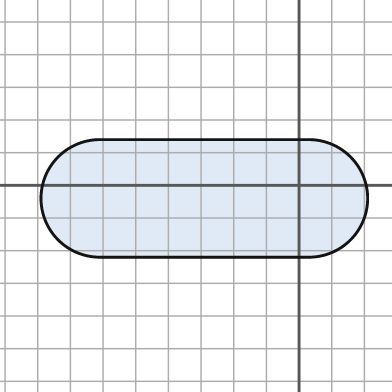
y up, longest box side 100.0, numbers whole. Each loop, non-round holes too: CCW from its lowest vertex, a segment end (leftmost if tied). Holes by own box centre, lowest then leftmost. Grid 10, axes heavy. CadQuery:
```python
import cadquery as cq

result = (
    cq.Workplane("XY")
    .moveTo(-61.0, -22.0)
    .lineTo(3.0, -22.0)
    .threePointArc((21.0, -4.0), (3.0, 14.0))
    .lineTo(-61.0, 14.0)
    .threePointArc((-79.0, -4.0), (-61.0, -22.0))
    .close()
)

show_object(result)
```